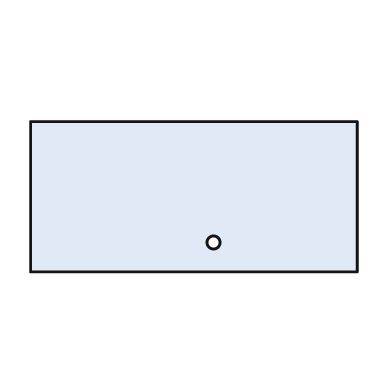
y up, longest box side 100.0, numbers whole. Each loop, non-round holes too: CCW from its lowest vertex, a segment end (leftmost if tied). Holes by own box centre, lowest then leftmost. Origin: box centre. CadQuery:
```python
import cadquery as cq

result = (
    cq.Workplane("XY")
    .moveTo(-50.0, -23.0)
    .lineTo(50.0, -23.0)
    .lineTo(50.0, 23.0)
    .lineTo(-50.0, 23.0)
    .close()
    .moveTo(6.0, -14.0)
    .circle(2.0)
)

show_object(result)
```